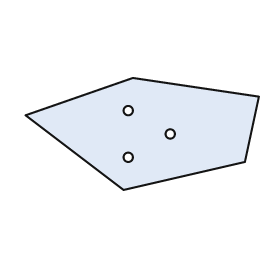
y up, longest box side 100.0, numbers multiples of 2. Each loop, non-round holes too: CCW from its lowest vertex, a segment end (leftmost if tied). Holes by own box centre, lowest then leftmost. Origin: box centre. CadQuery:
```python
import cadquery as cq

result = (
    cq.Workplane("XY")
    .moveTo(-8.0, -24.0)
    .lineTo(44.0, -12.0)
    .lineTo(50.0, 16.0)
    .lineTo(-4.0, 24.0)
    .lineTo(-50.0, 8.0)
    .close()
    .moveTo(-6.0, -10.0)
    .circle(2.0)
    .moveTo(12.0, 0.0)
    .circle(2.0)
    .moveTo(-6.0, 10.0)
    .circle(2.0)
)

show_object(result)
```